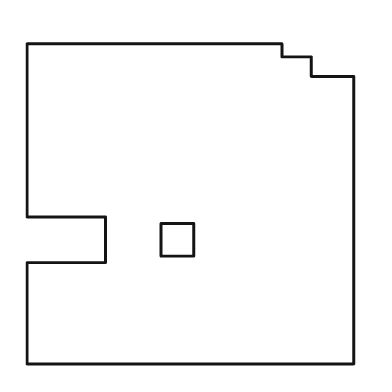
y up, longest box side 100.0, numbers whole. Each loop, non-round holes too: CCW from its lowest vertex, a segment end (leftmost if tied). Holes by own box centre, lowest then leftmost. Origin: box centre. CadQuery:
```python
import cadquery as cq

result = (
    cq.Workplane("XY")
    .moveTo(-50.0, -49.0)
    .lineTo(50.0, -49.0)
    .lineTo(50.0, 39.0)
    .lineTo(37.0, 39.0)
    .lineTo(37.0, 45.0)
    .lineTo(28.0, 45.0)
    .lineTo(28.0, 49.0)
    .lineTo(-50.0, 49.0)
    .lineTo(-50.0, -4.0)
    .lineTo(-26.0, -4.0)
    .lineTo(-26.0, -18.0)
    .lineTo(-50.0, -18.0)
    .close()
    .moveTo(-9.0, -16.0)
    .lineTo(1.0, -16.0)
    .lineTo(1.0, -6.0)
    .lineTo(-9.0, -6.0)
    .close()
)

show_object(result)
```